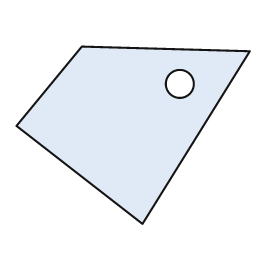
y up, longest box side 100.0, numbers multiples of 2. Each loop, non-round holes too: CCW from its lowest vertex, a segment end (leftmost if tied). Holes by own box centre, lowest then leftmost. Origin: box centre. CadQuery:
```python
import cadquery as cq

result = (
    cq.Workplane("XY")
    .moveTo(4.0, -38.0)
    .lineTo(50.0, 36.0)
    .lineTo(-22.0, 38.0)
    .lineTo(-50.0, 4.0)
    .close()
    .moveTo(20.0, 22.0)
    .circle(6.0)
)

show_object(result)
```